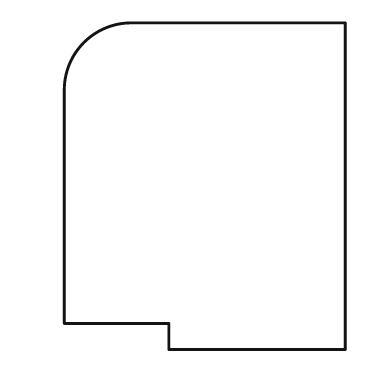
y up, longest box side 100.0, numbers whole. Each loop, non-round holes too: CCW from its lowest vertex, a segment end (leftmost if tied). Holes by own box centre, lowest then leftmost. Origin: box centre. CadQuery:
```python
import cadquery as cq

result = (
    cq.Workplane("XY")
    .moveTo(-11.0, -50.0)
    .lineTo(43.0, -50.0)
    .lineTo(43.0, 50.0)
    .lineTo(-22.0, 50.0)
    .threePointArc((-37.0, 44.0), (-43.0, 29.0))
    .lineTo(-43.0, -42.0)
    .lineTo(-11.0, -42.0)
    .close()
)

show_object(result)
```